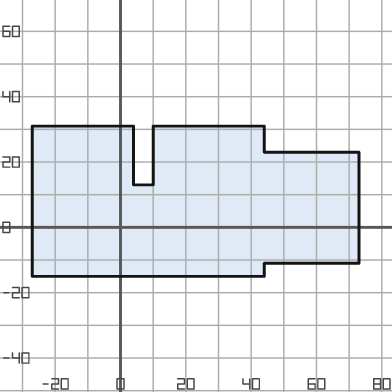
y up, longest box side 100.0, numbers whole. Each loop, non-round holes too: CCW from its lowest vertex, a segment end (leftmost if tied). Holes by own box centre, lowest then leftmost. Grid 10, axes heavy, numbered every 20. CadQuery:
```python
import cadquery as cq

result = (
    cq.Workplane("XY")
    .moveTo(-27.0, -15.0)
    .lineTo(44.0, -15.0)
    .lineTo(44.0, -11.0)
    .lineTo(73.0, -11.0)
    .lineTo(73.0, 23.0)
    .lineTo(44.0, 23.0)
    .lineTo(44.0, 31.0)
    .lineTo(10.0, 31.0)
    .lineTo(10.0, 13.0)
    .lineTo(4.0, 13.0)
    .lineTo(4.0, 31.0)
    .lineTo(-27.0, 31.0)
    .close()
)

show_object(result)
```